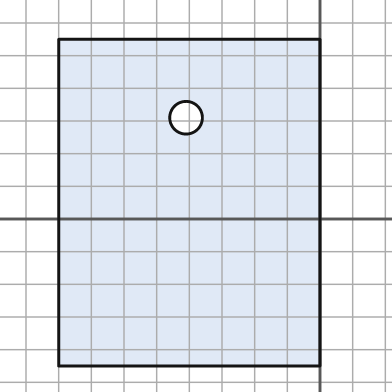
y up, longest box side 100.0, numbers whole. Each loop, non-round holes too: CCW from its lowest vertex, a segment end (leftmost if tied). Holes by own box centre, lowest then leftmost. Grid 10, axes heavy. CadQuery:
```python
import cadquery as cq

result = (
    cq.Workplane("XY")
    .moveTo(-80.0, -45.0)
    .lineTo(0.0, -45.0)
    .lineTo(0.0, 55.0)
    .lineTo(-80.0, 55.0)
    .close()
    .moveTo(-41.0, 31.0)
    .circle(5.0)
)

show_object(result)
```